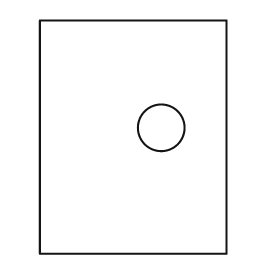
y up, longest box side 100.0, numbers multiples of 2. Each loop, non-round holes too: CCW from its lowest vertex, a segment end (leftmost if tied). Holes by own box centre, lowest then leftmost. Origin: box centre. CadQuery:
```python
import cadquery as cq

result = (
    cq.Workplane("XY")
    .moveTo(-40.0, -50.0)
    .lineTo(40.0, -50.0)
    .lineTo(40.0, 50.0)
    .lineTo(-40.0, 50.0)
    .close()
    .moveTo(12.0, 4.0)
    .circle(10.0)
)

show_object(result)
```